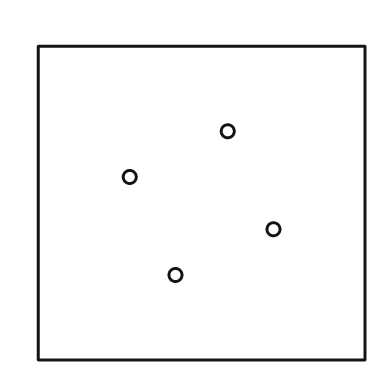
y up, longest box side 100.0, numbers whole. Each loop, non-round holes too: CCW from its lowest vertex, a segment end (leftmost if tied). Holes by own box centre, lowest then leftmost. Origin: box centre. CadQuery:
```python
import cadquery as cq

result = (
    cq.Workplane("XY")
    .moveTo(-50.0, -48.0)
    .lineTo(50.0, -48.0)
    .lineTo(50.0, 48.0)
    .lineTo(-50.0, 48.0)
    .close()
    .moveTo(-8.0, -22.0)
    .circle(2.0)
    .moveTo(22.0, -8.0)
    .circle(2.0)
    .moveTo(-22.0, 8.0)
    .circle(2.0)
    .moveTo(8.0, 22.0)
    .circle(2.0)
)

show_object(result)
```